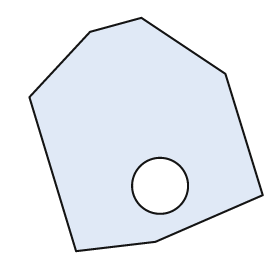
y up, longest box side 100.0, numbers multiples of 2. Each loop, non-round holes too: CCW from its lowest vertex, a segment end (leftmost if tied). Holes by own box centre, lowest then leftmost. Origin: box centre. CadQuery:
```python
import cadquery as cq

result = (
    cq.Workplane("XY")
    .moveTo(-30.0, -50.0)
    .lineTo(4.0, -46.0)
    .lineTo(50.0, -26.0)
    .lineTo(34.0, 26.0)
    .lineTo(-2.0, 50.0)
    .lineTo(-24.0, 44.0)
    .lineTo(-50.0, 16.0)
    .close()
    .moveTo(6.0, -22.0)
    .circle(12.0)
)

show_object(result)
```